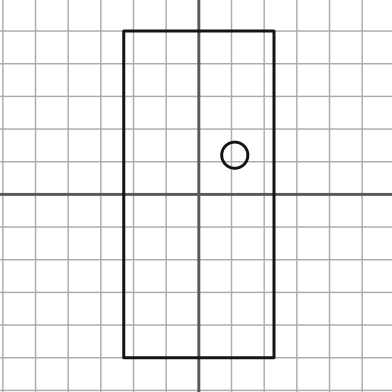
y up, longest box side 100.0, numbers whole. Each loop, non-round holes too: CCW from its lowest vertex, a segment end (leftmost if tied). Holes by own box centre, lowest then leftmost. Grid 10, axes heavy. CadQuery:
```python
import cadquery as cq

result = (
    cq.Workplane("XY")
    .moveTo(-23.0, -50.0)
    .lineTo(23.0, -50.0)
    .lineTo(23.0, 50.0)
    .lineTo(-23.0, 50.0)
    .close()
    .moveTo(11.0, 12.0)
    .circle(4.0)
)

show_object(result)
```